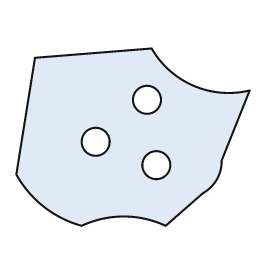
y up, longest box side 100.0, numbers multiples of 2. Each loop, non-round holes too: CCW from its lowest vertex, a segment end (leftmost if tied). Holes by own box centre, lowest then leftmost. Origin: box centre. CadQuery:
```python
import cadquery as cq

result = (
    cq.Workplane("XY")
    .moveTo(-22.0, -38.0)
    .threePointArc((-4.0, -34.0), (14.0, -38.0))
    .lineTo(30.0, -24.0)
    .threePointArc((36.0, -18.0), (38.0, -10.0))
    .lineTo(50.0, 20.0)
    .threePointArc((26.0, 22.0), (8.0, 38.0))
    .lineTo(-42.0, 34.0)
    .lineTo(-50.0, -16.0)
    .threePointArc((-38.0, -30.0), (-22.0, -38.0))
    .close()
    .moveTo(10.0, -12.0)
    .circle(6.0)
    .moveTo(-16.0, -2.0)
    .circle(6.0)
    .moveTo(6.0, 16.0)
    .circle(6.0)
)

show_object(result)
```